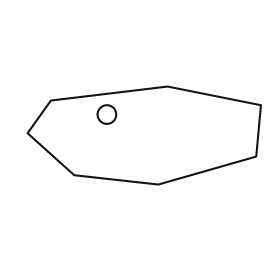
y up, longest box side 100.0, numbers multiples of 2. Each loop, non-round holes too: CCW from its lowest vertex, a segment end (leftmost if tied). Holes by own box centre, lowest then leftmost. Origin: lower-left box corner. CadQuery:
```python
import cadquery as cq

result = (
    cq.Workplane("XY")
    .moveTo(56.0, 0.0)
    .lineTo(98.0, 12.0)
    .lineTo(100.0, 34.0)
    .lineTo(60.0, 42.0)
    .lineTo(10.0, 36.0)
    .lineTo(0.0, 22.0)
    .lineTo(20.0, 4.0)
    .close()
    .moveTo(34.0, 30.0)
    .circle(4.0)
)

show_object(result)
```